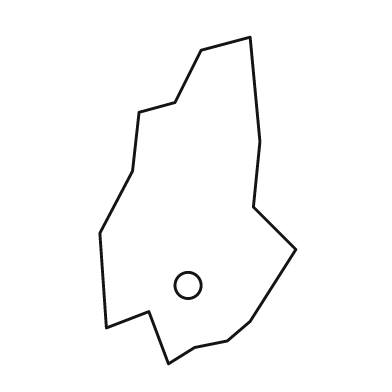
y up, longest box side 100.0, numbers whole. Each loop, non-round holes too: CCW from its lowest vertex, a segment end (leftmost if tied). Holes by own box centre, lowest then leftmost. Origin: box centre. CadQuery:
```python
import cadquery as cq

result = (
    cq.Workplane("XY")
    .moveTo(-9.0, -50.0)
    .lineTo(-1.0, -45.0)
    .lineTo(9.0, -43.0)
    .lineTo(16.0, -37.0)
    .lineTo(30.0, -15.0)
    .lineTo(17.0, -2.0)
    .lineTo(19.0, 18.0)
    .lineTo(16.0, 50.0)
    .lineTo(1.0, 46.0)
    .lineTo(-7.0, 30.0)
    .lineTo(-18.0, 27.0)
    .lineTo(-20.0, 9.0)
    .lineTo(-30.0, -10.0)
    .lineTo(-28.0, -39.0)
    .lineTo(-15.0, -34.0)
    .close()
    .moveTo(-3.0, -26.0)
    .circle(4.0)
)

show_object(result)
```